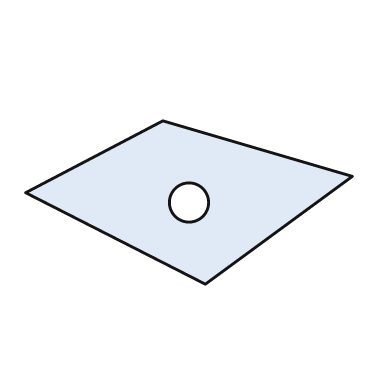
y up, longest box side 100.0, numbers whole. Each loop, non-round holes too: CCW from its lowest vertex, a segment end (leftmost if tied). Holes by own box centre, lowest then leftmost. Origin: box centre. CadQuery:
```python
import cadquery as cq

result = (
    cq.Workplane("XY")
    .moveTo(5.0, -25.0)
    .lineTo(50.0, 8.0)
    .lineTo(-8.0, 25.0)
    .lineTo(-50.0, 3.0)
    .close()
    .moveTo(0.0, 0.0)
    .circle(6.0)
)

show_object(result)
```